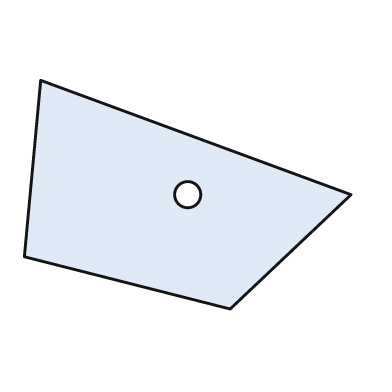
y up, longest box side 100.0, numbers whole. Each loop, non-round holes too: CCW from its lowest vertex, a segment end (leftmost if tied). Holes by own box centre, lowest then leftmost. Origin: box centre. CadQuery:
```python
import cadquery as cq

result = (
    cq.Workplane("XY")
    .moveTo(13.0, -35.0)
    .lineTo(50.0, 0.0)
    .lineTo(-45.0, 35.0)
    .lineTo(-50.0, -19.0)
    .close()
    .moveTo(0.0, 0.0)
    .circle(4.0)
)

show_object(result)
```